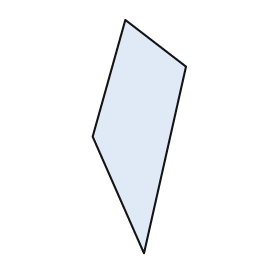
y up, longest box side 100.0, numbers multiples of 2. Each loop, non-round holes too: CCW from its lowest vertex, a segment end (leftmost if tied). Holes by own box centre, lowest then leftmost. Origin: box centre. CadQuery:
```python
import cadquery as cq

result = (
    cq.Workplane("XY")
    .moveTo(2.0, -50.0)
    .lineTo(20.0, 30.0)
    .lineTo(-6.0, 50.0)
    .lineTo(-20.0, 0.0)
    .close()
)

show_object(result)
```